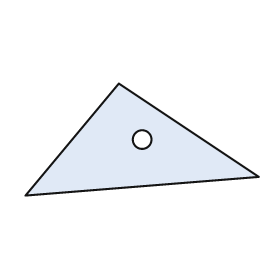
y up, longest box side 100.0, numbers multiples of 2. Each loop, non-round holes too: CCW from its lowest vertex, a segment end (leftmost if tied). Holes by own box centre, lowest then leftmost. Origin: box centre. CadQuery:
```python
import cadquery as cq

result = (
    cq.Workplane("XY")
    .moveTo(-50.0, -24.0)
    .lineTo(50.0, -16.0)
    .lineTo(-10.0, 24.0)
    .close()
    .moveTo(0.0, 0.0)
    .circle(4.0)
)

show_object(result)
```